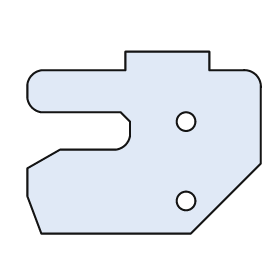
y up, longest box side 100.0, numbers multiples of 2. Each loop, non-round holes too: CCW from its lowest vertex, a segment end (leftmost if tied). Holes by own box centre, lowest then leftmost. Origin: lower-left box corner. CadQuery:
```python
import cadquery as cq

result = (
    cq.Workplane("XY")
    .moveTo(6.0, 0.0)
    .lineTo(70.0, 0.0)
    .lineTo(100.0, 30.0)
    .lineTo(100.0, 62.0)
    .threePointArc((98.0, 68.0), (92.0, 70.0))
    .lineTo(78.0, 70.0)
    .lineTo(78.0, 78.0)
    .lineTo(42.0, 78.0)
    .lineTo(42.0, 70.0)
    .lineTo(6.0, 70.0)
    .threePointArc((2.0, 68.0), (0.0, 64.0))
    .lineTo(0.0, 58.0)
    .threePointArc((2.0, 54.0), (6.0, 52.0))
    .lineTo(40.0, 52.0)
    .lineTo(44.0, 48.0)
    .lineTo(44.0, 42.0)
    .threePointArc((42.0, 38.0), (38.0, 36.0))
    .lineTo(14.0, 36.0)
    .lineTo(0.0, 28.0)
    .lineTo(0.0, 16.0)
    .close()
    .moveTo(68.0, 14.0)
    .circle(4.0)
    .moveTo(68.0, 48.0)
    .circle(4.0)
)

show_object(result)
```